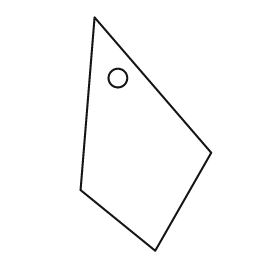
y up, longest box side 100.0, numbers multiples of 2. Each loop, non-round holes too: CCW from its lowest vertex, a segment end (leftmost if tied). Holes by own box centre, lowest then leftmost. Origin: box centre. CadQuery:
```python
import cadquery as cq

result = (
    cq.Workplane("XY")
    .moveTo(4.0, -50.0)
    .lineTo(28.0, -8.0)
    .lineTo(-22.0, 50.0)
    .lineTo(-28.0, -24.0)
    .close()
    .moveTo(-12.0, 24.0)
    .circle(4.0)
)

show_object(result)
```